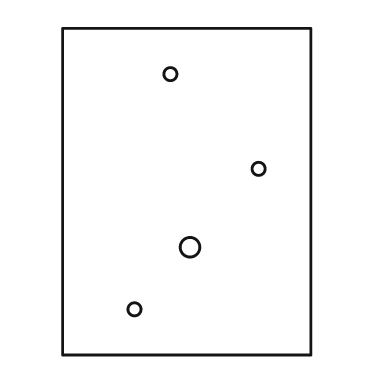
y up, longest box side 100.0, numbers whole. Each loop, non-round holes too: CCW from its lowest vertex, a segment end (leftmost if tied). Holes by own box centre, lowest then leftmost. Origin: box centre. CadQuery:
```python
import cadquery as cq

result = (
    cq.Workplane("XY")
    .moveTo(-38.0, -50.0)
    .lineTo(38.0, -50.0)
    .lineTo(38.0, 50.0)
    .lineTo(-38.0, 50.0)
    .close()
    .moveTo(-16.0, -36.0)
    .circle(2.0)
    .moveTo(1.0, -17.0)
    .circle(3.0)
    .moveTo(22.0, 7.0)
    .circle(2.0)
    .moveTo(-5.0, 36.0)
    .circle(2.0)
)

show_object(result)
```